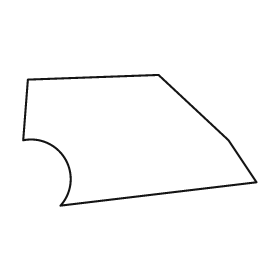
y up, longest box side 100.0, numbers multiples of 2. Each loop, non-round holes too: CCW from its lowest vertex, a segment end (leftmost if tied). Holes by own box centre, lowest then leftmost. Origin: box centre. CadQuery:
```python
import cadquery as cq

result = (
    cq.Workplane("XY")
    .moveTo(-34.0, -28.0)
    .lineTo(50.0, -18.0)
    .lineTo(38.0, 0.0)
    .lineTo(8.0, 28.0)
    .lineTo(-48.0, 26.0)
    .lineTo(-50.0, 0.0)
    .threePointArc((-32.0, -8.0), (-34.0, -28.0))
    .close()
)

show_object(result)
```